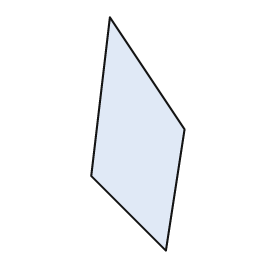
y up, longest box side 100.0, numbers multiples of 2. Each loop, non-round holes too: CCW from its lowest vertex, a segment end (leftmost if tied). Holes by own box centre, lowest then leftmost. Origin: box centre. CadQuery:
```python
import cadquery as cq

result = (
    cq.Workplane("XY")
    .moveTo(12.0, -50.0)
    .lineTo(20.0, 2.0)
    .lineTo(-12.0, 50.0)
    .lineTo(-20.0, -18.0)
    .close()
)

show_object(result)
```